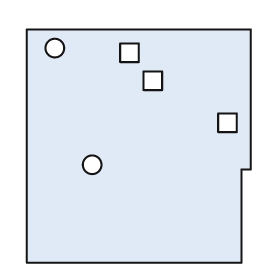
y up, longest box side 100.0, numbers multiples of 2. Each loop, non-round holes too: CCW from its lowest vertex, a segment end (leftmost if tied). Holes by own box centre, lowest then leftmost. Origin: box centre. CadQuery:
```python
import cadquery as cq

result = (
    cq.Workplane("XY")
    .moveTo(-48.0, -50.0)
    .lineTo(44.0, -50.0)
    .lineTo(44.0, -10.0)
    .lineTo(48.0, -10.0)
    .lineTo(48.0, 50.0)
    .lineTo(-48.0, 50.0)
    .close()
    .moveTo(-20.0, -8.0)
    .circle(4.0)
    .moveTo(34.0, 6.0)
    .lineTo(42.0, 6.0)
    .lineTo(42.0, 14.0)
    .lineTo(34.0, 14.0)
    .close()
    .moveTo(2.0, 24.0)
    .lineTo(10.0, 24.0)
    .lineTo(10.0, 32.0)
    .lineTo(2.0, 32.0)
    .close()
    .moveTo(-8.0, 36.0)
    .lineTo(0.0, 36.0)
    .lineTo(0.0, 44.0)
    .lineTo(-8.0, 44.0)
    .close()
    .moveTo(-36.0, 42.0)
    .circle(4.0)
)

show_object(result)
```